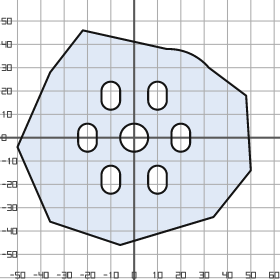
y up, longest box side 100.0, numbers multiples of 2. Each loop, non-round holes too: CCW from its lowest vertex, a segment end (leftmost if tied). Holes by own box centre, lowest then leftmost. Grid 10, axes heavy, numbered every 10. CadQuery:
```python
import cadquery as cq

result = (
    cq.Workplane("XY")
    .moveTo(-6.0, -46.0)
    .lineTo(34.0, -34.0)
    .lineTo(50.0, -14.0)
    .lineTo(48.0, 18.0)
    .lineTo(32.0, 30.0)
    .threePointArc((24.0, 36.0), (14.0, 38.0))
    .lineTo(-22.0, 46.0)
    .lineTo(-36.0, 28.0)
    .lineTo(-50.0, -4.0)
    .lineTo(-36.0, -36.0)
    .close()
    .moveTo(-14.0, -20.0)
    .threePointArc((-10.0, -24.0), (-6.0, -20.0))
    .lineTo(-6.0, -16.0)
    .threePointArc((-10.0, -12.0), (-14.0, -16.0))
    .close()
    .moveTo(6.0, -20.0)
    .threePointArc((10.0, -24.0), (14.0, -20.0))
    .lineTo(14.0, -16.0)
    .threePointArc((10.0, -12.0), (6.0, -16.0))
    .close()
    .moveTo(-24.0, -2.0)
    .threePointArc((-20.0, -6.0), (-16.0, -2.0))
    .lineTo(-16.0, 2.0)
    .threePointArc((-20.0, 6.0), (-24.0, 2.0))
    .close()
    .moveTo(0.0, 0.0)
    .circle(6.0)
    .moveTo(16.0, -2.0)
    .threePointArc((20.0, -6.0), (24.0, -2.0))
    .lineTo(24.0, 2.0)
    .threePointArc((20.0, 6.0), (16.0, 2.0))
    .close()
    .moveTo(-14.0, 16.0)
    .threePointArc((-10.0, 12.0), (-6.0, 16.0))
    .lineTo(-6.0, 20.0)
    .threePointArc((-10.0, 24.0), (-14.0, 20.0))
    .close()
    .moveTo(6.0, 16.0)
    .threePointArc((10.0, 12.0), (14.0, 16.0))
    .lineTo(14.0, 20.0)
    .threePointArc((10.0, 24.0), (6.0, 20.0))
    .close()
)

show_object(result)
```